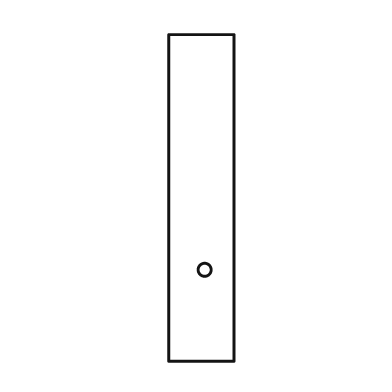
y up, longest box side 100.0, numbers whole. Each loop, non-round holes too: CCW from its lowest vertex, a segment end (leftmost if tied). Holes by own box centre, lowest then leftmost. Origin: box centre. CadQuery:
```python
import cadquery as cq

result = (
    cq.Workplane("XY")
    .moveTo(-10.0, -50.0)
    .lineTo(10.0, -50.0)
    .lineTo(10.0, 50.0)
    .lineTo(-10.0, 50.0)
    .close()
    .moveTo(1.0, -22.0)
    .circle(2.0)
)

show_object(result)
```